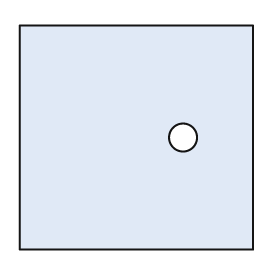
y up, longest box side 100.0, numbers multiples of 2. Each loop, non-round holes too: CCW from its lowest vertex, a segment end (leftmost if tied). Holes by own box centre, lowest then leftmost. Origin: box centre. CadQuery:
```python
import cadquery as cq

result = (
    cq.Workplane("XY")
    .moveTo(-50.0, -48.0)
    .lineTo(50.0, -48.0)
    .lineTo(50.0, 48.0)
    .lineTo(-50.0, 48.0)
    .close()
    .moveTo(20.0, 0.0)
    .circle(6.0)
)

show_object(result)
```